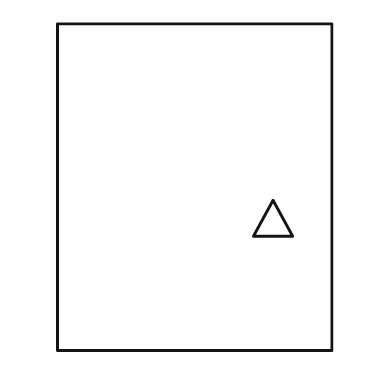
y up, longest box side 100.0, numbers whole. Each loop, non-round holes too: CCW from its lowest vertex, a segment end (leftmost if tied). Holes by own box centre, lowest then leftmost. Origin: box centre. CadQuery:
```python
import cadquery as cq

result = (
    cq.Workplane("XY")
    .moveTo(-42.0, -50.0)
    .lineTo(42.0, -50.0)
    .lineTo(42.0, 50.0)
    .lineTo(-42.0, 50.0)
    .close()
    .moveTo(18.0, -15.0)
    .lineTo(30.0, -15.0)
    .lineTo(24.0, -4.0)
    .close()
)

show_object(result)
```